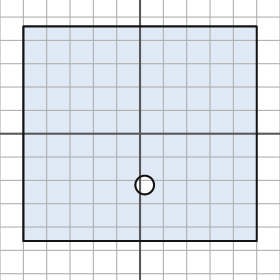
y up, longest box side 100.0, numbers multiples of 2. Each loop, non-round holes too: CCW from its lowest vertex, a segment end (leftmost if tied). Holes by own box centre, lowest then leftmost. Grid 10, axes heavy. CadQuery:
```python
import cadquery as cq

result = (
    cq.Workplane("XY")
    .moveTo(-50.0, -46.0)
    .lineTo(50.0, -46.0)
    .lineTo(50.0, 46.0)
    .lineTo(-50.0, 46.0)
    .close()
    .moveTo(2.0, -22.0)
    .circle(4.0)
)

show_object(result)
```